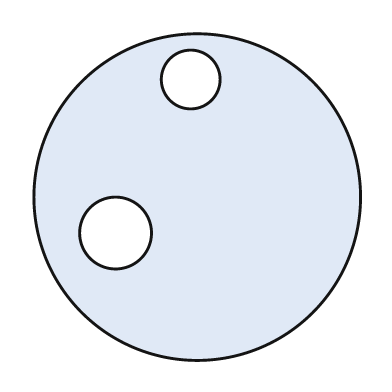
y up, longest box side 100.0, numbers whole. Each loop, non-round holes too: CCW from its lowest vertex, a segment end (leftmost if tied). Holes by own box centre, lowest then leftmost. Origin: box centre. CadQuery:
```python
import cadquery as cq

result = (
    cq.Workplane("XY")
    .moveTo(0.0, 0.0)
    .circle(50.0)
    .moveTo(-25.0, -11.0)
    .circle(11.0)
    .moveTo(-2.0, 36.0)
    .circle(9.0)
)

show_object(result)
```